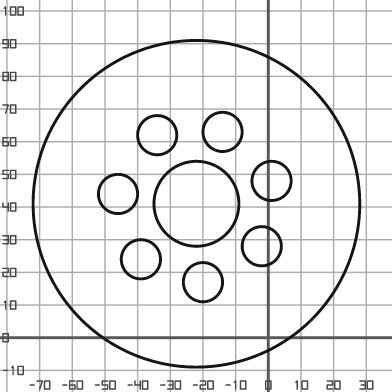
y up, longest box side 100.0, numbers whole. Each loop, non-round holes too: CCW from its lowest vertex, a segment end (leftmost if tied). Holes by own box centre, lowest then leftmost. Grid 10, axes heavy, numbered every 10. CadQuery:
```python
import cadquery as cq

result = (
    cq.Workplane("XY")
    .moveTo(-22.0, 41.0)
    .circle(50.0)
    .moveTo(-20.0, 17.0)
    .circle(6.0)
    .moveTo(-39.0, 24.0)
    .circle(6.0)
    .moveTo(-2.0, 28.0)
    .circle(6.0)
    .moveTo(-22.0, 41.0)
    .circle(13.0)
    .moveTo(-46.0, 44.0)
    .circle(6.0)
    .moveTo(1.0, 48.0)
    .circle(6.0)
    .moveTo(-34.0, 62.0)
    .circle(6.0)
    .moveTo(-14.0, 63.0)
    .circle(6.0)
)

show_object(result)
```